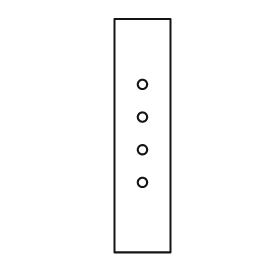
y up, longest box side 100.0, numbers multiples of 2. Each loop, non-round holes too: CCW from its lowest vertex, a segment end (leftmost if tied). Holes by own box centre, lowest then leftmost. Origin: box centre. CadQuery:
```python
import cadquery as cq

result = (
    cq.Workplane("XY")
    .moveTo(-12.0, -50.0)
    .lineTo(12.0, -50.0)
    .lineTo(12.0, 50.0)
    .lineTo(-12.0, 50.0)
    .close()
    .moveTo(0.0, -20.0)
    .circle(2.0)
    .moveTo(0.0, -6.0)
    .circle(2.0)
    .moveTo(0.0, 8.0)
    .circle(2.0)
    .moveTo(0.0, 22.0)
    .circle(2.0)
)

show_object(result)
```